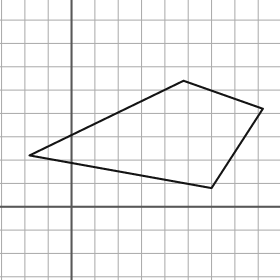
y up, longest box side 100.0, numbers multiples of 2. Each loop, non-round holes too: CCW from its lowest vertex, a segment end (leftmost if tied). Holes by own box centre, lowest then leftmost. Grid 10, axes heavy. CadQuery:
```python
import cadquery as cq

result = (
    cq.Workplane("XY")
    .moveTo(60.0, 8.0)
    .lineTo(82.0, 42.0)
    .lineTo(48.0, 54.0)
    .lineTo(-18.0, 22.0)
    .close()
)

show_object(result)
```